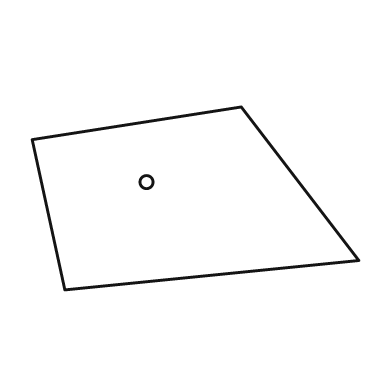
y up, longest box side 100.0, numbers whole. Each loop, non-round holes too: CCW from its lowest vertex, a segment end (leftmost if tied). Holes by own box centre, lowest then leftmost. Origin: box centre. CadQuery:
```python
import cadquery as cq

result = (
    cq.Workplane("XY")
    .moveTo(-40.0, -28.0)
    .lineTo(50.0, -19.0)
    .lineTo(14.0, 28.0)
    .lineTo(-50.0, 18.0)
    .close()
    .moveTo(-15.0, 5.0)
    .circle(2.0)
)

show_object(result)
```